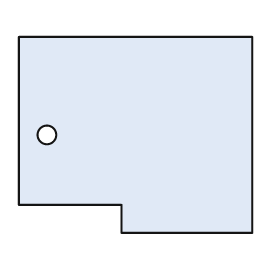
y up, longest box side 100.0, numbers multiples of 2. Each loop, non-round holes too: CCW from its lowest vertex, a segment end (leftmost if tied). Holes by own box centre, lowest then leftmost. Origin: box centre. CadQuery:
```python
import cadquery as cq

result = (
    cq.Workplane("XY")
    .moveTo(-6.0, -42.0)
    .lineTo(50.0, -42.0)
    .lineTo(50.0, 42.0)
    .lineTo(-50.0, 42.0)
    .lineTo(-50.0, -30.0)
    .lineTo(-6.0, -30.0)
    .close()
    .moveTo(-38.0, 0.0)
    .circle(4.0)
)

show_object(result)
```